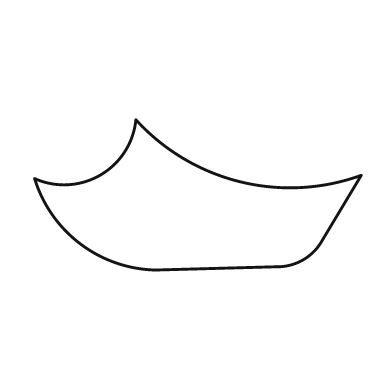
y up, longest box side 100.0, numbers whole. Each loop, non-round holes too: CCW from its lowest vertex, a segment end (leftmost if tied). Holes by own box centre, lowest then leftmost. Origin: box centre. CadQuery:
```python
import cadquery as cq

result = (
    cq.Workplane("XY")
    .moveTo(-13.0, -23.0)
    .lineTo(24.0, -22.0)
    .threePointArc((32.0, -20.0), (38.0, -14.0))
    .lineTo(50.0, 6.0)
    .threePointArc((13.0, 4.0), (-19.0, 23.0))
    .threePointArc((-30.0, 6.0), (-50.0, 5.0))
    .threePointArc((-36.0, -15.0), (-13.0, -23.0))
    .close()
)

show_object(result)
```